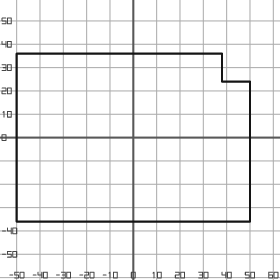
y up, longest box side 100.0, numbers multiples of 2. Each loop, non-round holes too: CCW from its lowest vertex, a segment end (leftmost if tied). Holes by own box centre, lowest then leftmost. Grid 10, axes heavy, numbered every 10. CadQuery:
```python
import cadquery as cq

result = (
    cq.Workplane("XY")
    .moveTo(-50.0, -36.0)
    .lineTo(50.0, -36.0)
    .lineTo(50.0, 24.0)
    .lineTo(38.0, 24.0)
    .lineTo(38.0, 36.0)
    .lineTo(-50.0, 36.0)
    .close()
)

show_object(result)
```